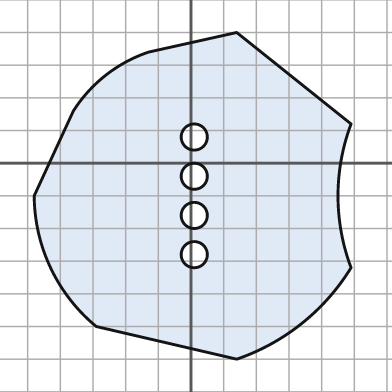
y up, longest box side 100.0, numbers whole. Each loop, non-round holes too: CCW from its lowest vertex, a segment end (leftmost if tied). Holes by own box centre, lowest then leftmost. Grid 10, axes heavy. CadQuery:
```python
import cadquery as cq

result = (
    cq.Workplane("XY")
    .moveTo(14.0, -60.0)
    .threePointArc((34.0, -49.0), (49.0, -32.0))
    .threePointArc((45.0, -10.0), (49.0, 12.0))
    .lineTo(14.0, 40.0)
    .lineTo(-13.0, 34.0)
    .threePointArc((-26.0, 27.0), (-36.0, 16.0))
    .lineTo(-48.0, -10.0)
    .threePointArc((-43.0, -32.0), (-29.0, -50.0))
    .close()
    .moveTo(1.0, -28.0)
    .circle(4.0)
    .moveTo(1.0, -16.0)
    .circle(4.0)
    .moveTo(1.0, -4.0)
    .circle(4.0)
    .moveTo(1.0, 8.0)
    .circle(4.0)
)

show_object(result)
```